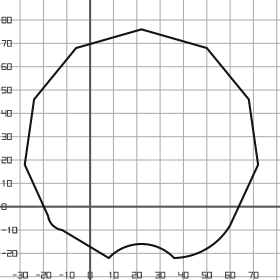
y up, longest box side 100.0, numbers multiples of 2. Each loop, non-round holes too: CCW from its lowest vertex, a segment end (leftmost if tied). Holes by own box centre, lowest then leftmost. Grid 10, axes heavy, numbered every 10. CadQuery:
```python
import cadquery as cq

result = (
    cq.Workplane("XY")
    .moveTo(8.0, -22.0)
    .threePointArc((22.0, -16.0), (36.0, -22.0))
    .threePointArc((50.0, -18.0), (60.0, -8.0))
    .lineTo(72.0, 18.0)
    .lineTo(68.0, 46.0)
    .lineTo(50.0, 68.0)
    .lineTo(22.0, 76.0)
    .lineTo(-6.0, 68.0)
    .lineTo(-24.0, 46.0)
    .lineTo(-28.0, 18.0)
    .lineTo(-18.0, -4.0)
    .threePointArc((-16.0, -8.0), (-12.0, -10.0))
    .close()
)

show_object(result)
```